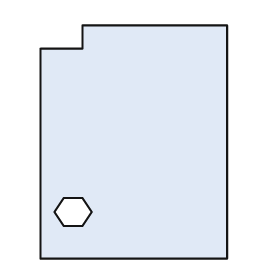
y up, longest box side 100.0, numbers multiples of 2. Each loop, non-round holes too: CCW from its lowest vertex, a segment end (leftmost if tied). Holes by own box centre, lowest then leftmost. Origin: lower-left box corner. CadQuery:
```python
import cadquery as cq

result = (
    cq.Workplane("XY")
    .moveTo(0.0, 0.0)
    .lineTo(80.0, 0.0)
    .lineTo(80.0, 100.0)
    .lineTo(18.0, 100.0)
    .lineTo(18.0, 90.0)
    .lineTo(0.0, 90.0)
    .close()
    .moveTo(10.0, 14.0)
    .lineTo(18.0, 14.0)
    .lineTo(22.0, 20.0)
    .lineTo(18.0, 26.0)
    .lineTo(10.0, 26.0)
    .lineTo(6.0, 20.0)
    .close()
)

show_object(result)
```